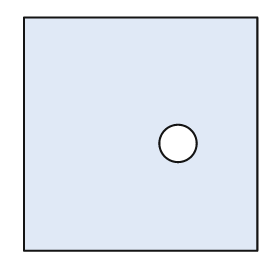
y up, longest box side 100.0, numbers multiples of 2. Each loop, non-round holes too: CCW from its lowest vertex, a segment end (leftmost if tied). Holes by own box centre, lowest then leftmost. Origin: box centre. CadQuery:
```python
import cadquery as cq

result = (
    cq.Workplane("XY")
    .moveTo(-50.0, -50.0)
    .lineTo(50.0, -50.0)
    .lineTo(50.0, 50.0)
    .lineTo(-50.0, 50.0)
    .close()
    .moveTo(16.0, -4.0)
    .circle(8.0)
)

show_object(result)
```